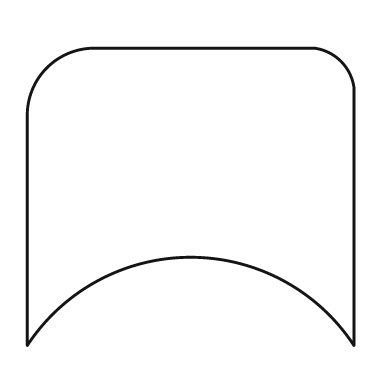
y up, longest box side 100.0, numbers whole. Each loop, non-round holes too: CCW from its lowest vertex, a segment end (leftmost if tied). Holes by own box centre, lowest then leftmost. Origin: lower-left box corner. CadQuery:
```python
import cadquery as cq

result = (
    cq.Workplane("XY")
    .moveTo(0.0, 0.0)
    .threePointArc((50.0, 27.0), (100.0, 0.0))
    .lineTo(100.0, 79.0)
    .threePointArc((96.0, 87.0), (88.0, 91.0))
    .lineTo(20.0, 91.0)
    .threePointArc((6.0, 85.0), (0.0, 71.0))
    .close()
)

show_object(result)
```